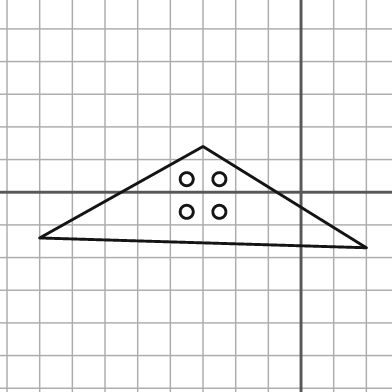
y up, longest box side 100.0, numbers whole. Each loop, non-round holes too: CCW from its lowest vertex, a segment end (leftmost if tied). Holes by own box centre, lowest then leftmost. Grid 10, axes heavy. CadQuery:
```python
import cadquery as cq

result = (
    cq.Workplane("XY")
    .moveTo(20.0, -17.0)
    .lineTo(-30.0, 14.0)
    .lineTo(-80.0, -14.0)
    .close()
    .moveTo(-35.0, -6.0)
    .circle(2.0)
    .moveTo(-25.0, -6.0)
    .circle(2.0)
    .moveTo(-35.0, 4.0)
    .circle(2.0)
    .moveTo(-25.0, 4.0)
    .circle(2.0)
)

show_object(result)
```